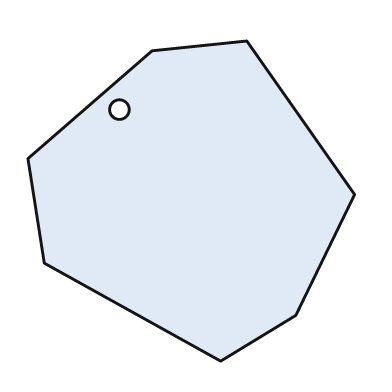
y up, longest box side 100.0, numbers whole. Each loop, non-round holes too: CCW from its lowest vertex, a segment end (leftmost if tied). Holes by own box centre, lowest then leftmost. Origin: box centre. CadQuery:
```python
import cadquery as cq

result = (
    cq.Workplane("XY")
    .moveTo(9.0, -49.0)
    .lineTo(32.0, -35.0)
    .lineTo(50.0, 2.0)
    .lineTo(17.0, 49.0)
    .lineTo(-12.0, 46.0)
    .lineTo(-50.0, 13.0)
    .lineTo(-45.0, -19.0)
    .close()
    .moveTo(-22.0, 28.0)
    .circle(3.0)
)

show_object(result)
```